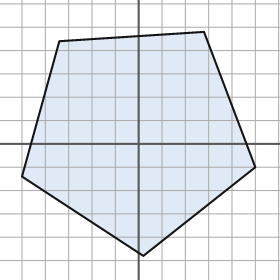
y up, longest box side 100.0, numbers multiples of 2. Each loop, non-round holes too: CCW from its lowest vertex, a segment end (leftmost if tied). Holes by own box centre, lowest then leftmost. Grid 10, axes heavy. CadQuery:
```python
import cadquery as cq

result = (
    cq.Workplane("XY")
    .moveTo(2.0, -48.0)
    .lineTo(50.0, -10.0)
    .lineTo(28.0, 48.0)
    .lineTo(-34.0, 44.0)
    .lineTo(-50.0, -14.0)
    .close()
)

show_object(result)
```